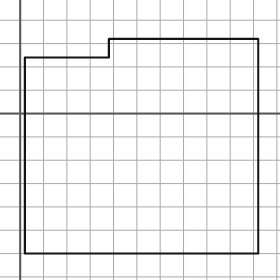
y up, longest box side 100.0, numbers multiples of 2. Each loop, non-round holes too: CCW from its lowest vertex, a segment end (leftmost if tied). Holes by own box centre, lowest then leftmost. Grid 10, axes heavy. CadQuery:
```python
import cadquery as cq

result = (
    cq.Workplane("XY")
    .moveTo(2.0, -60.0)
    .lineTo(102.0, -60.0)
    .lineTo(102.0, 32.0)
    .lineTo(38.0, 32.0)
    .lineTo(38.0, 24.0)
    .lineTo(2.0, 24.0)
    .close()
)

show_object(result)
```